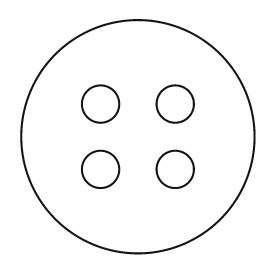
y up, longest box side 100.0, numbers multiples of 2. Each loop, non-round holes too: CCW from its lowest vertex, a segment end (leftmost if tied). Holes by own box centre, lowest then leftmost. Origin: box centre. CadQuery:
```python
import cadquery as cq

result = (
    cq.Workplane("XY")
    .moveTo(0.0, 0.0)
    .circle(50.0)
    .moveTo(-16.0, -14.0)
    .circle(8.0)
    .moveTo(16.0, -14.0)
    .circle(8.0)
    .moveTo(-16.0, 14.0)
    .circle(8.0)
    .moveTo(16.0, 14.0)
    .circle(8.0)
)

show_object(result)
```